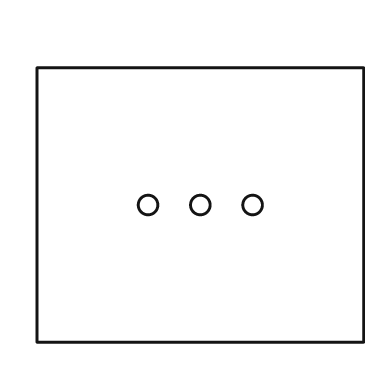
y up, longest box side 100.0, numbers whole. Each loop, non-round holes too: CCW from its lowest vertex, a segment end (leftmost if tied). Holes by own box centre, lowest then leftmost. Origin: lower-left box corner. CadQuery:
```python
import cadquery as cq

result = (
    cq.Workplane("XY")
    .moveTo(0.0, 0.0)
    .lineTo(100.0, 0.0)
    .lineTo(100.0, 84.0)
    .lineTo(0.0, 84.0)
    .close()
    .moveTo(34.0, 42.0)
    .circle(3.0)
    .moveTo(50.0, 42.0)
    .circle(3.0)
    .moveTo(66.0, 42.0)
    .circle(3.0)
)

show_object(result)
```